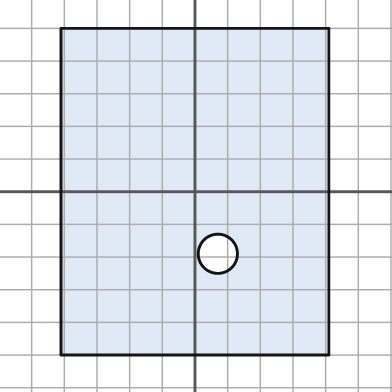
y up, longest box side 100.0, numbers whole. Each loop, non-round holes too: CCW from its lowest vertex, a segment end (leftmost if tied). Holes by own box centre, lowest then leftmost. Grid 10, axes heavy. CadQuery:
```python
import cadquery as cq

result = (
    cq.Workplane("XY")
    .moveTo(-41.0, -50.0)
    .lineTo(41.0, -50.0)
    .lineTo(41.0, 50.0)
    .lineTo(-41.0, 50.0)
    .close()
    .moveTo(7.0, -19.0)
    .circle(6.0)
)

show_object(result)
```